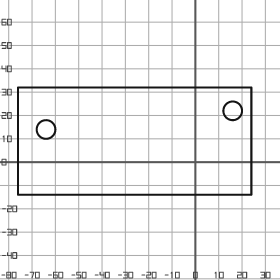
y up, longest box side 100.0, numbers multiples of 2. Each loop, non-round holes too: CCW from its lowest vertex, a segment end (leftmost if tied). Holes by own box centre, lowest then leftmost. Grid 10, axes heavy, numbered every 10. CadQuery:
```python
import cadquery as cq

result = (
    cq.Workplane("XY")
    .moveTo(-76.0, -14.0)
    .lineTo(24.0, -14.0)
    .lineTo(24.0, 32.0)
    .lineTo(-76.0, 32.0)
    .close()
    .moveTo(-64.0, 14.0)
    .circle(4.0)
    .moveTo(16.0, 22.0)
    .circle(4.0)
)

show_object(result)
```